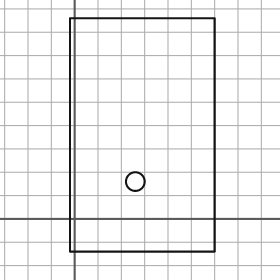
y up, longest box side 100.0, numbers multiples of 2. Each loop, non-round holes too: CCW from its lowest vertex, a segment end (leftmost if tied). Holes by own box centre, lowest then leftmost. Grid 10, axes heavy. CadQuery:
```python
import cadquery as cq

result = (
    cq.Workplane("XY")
    .moveTo(-2.0, -14.0)
    .lineTo(60.0, -14.0)
    .lineTo(60.0, 86.0)
    .lineTo(-2.0, 86.0)
    .close()
    .moveTo(26.0, 16.0)
    .circle(4.0)
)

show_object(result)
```